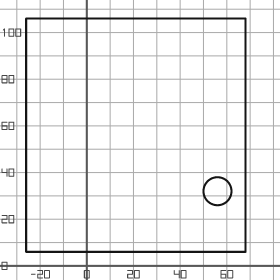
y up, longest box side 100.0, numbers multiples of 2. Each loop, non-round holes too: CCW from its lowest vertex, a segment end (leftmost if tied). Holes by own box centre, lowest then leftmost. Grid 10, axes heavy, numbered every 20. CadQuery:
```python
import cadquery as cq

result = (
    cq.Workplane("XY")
    .moveTo(-26.0, 6.0)
    .lineTo(68.0, 6.0)
    .lineTo(68.0, 106.0)
    .lineTo(-26.0, 106.0)
    .close()
    .moveTo(56.0, 32.0)
    .circle(6.0)
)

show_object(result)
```